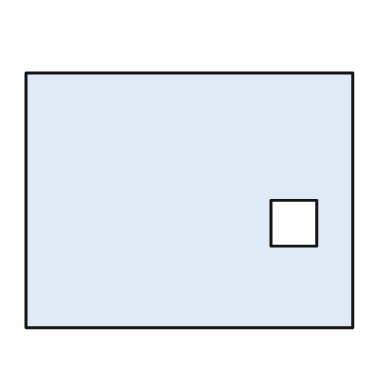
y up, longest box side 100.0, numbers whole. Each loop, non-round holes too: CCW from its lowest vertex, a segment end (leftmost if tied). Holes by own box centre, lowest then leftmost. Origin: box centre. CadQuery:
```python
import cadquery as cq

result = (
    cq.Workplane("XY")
    .moveTo(-50.0, -39.0)
    .lineTo(50.0, -39.0)
    .lineTo(50.0, 39.0)
    .lineTo(-50.0, 39.0)
    .close()
    .moveTo(25.0, -14.0)
    .lineTo(39.0, -14.0)
    .lineTo(39.0, 0.0)
    .lineTo(25.0, 0.0)
    .close()
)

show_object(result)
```